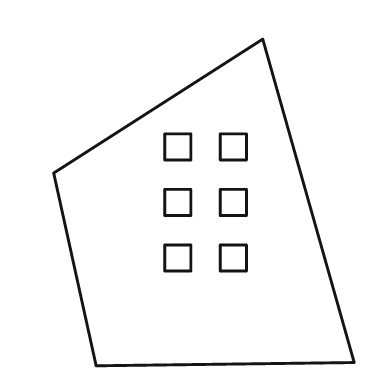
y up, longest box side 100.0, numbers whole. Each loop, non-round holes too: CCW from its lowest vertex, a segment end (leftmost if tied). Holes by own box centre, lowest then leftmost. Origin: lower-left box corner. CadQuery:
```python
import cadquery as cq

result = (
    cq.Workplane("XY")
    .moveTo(13.0, 0.0)
    .lineTo(92.0, 1.0)
    .lineTo(64.0, 100.0)
    .lineTo(0.0, 59.0)
    .close()
    .moveTo(34.0, 29.0)
    .lineTo(42.0, 29.0)
    .lineTo(42.0, 37.0)
    .lineTo(34.0, 37.0)
    .close()
    .moveTo(51.0, 29.0)
    .lineTo(59.0, 29.0)
    .lineTo(59.0, 37.0)
    .lineTo(51.0, 37.0)
    .close()
    .moveTo(34.0, 46.0)
    .lineTo(42.0, 46.0)
    .lineTo(42.0, 54.0)
    .lineTo(34.0, 54.0)
    .close()
    .moveTo(51.0, 46.0)
    .lineTo(59.0, 46.0)
    .lineTo(59.0, 54.0)
    .lineTo(51.0, 54.0)
    .close()
    .moveTo(34.0, 63.0)
    .lineTo(42.0, 63.0)
    .lineTo(42.0, 71.0)
    .lineTo(34.0, 71.0)
    .close()
    .moveTo(51.0, 63.0)
    .lineTo(59.0, 63.0)
    .lineTo(59.0, 71.0)
    .lineTo(51.0, 71.0)
    .close()
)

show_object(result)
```